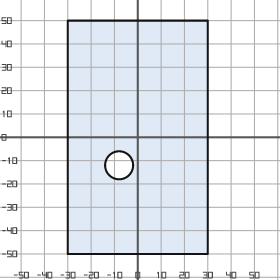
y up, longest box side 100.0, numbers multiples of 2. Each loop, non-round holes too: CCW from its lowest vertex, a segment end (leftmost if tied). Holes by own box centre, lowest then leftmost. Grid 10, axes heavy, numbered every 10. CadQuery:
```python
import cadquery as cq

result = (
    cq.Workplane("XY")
    .moveTo(-30.0, -50.0)
    .lineTo(30.0, -50.0)
    .lineTo(30.0, 50.0)
    .lineTo(-30.0, 50.0)
    .close()
    .moveTo(-8.0, -12.0)
    .circle(6.0)
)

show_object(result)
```